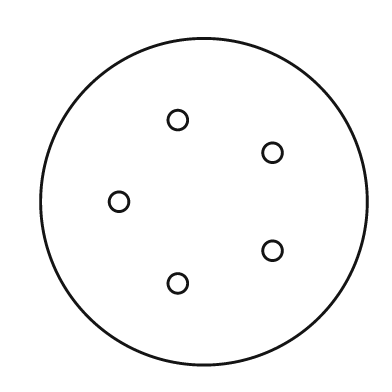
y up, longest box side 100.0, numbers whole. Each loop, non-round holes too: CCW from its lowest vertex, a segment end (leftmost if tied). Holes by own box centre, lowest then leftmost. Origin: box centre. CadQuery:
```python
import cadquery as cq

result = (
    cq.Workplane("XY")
    .moveTo(0.0, 0.0)
    .circle(50.0)
    .moveTo(-8.0, -25.0)
    .circle(3.0)
    .moveTo(21.0, -15.0)
    .circle(3.0)
    .moveTo(-26.0, 0.0)
    .circle(3.0)
    .moveTo(21.0, 15.0)
    .circle(3.0)
    .moveTo(-8.0, 25.0)
    .circle(3.0)
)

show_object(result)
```